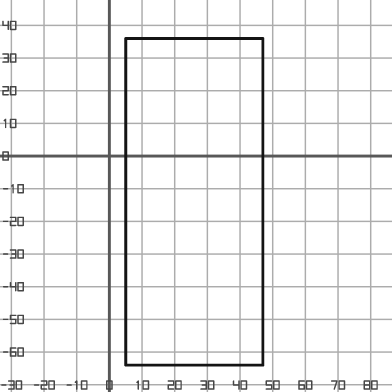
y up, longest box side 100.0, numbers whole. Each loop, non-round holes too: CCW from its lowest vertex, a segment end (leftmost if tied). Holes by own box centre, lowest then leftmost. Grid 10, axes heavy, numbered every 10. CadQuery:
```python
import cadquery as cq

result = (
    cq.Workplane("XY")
    .moveTo(5.0, -64.0)
    .lineTo(47.0, -64.0)
    .lineTo(47.0, 36.0)
    .lineTo(5.0, 36.0)
    .close()
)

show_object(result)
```